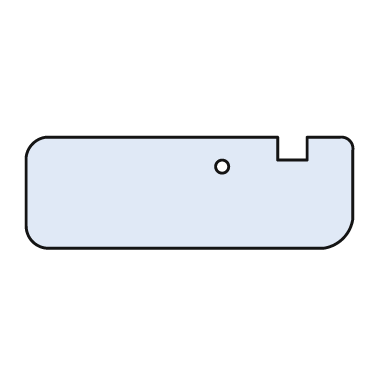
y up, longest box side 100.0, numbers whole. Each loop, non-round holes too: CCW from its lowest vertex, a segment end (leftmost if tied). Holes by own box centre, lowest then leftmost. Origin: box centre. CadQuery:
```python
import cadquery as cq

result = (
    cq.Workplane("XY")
    .moveTo(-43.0, -17.0)
    .lineTo(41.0, -17.0)
    .threePointArc((47.0, -14.0), (50.0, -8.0))
    .lineTo(50.0, 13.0)
    .threePointArc((49.0, 16.0), (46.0, 17.0))
    .lineTo(36.0, 17.0)
    .lineTo(36.0, 10.0)
    .lineTo(27.0, 10.0)
    .lineTo(27.0, 17.0)
    .lineTo(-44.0, 17.0)
    .threePointArc((-48.0, 15.0), (-50.0, 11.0))
    .lineTo(-50.0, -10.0)
    .threePointArc((-48.0, -15.0), (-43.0, -17.0))
    .close()
    .moveTo(10.0, 8.0)
    .circle(2.0)
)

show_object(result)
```